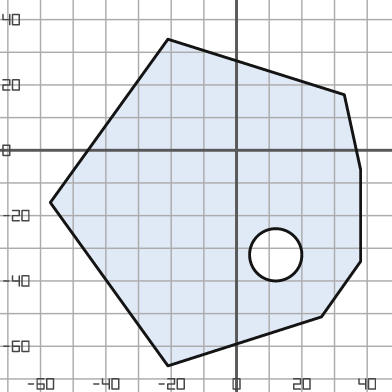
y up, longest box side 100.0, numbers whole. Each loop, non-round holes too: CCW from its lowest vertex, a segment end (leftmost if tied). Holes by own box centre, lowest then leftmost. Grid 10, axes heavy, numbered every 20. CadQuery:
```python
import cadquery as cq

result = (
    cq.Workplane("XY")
    .moveTo(-21.0, -66.0)
    .lineTo(26.0, -51.0)
    .lineTo(38.0, -34.0)
    .lineTo(38.0, -6.0)
    .lineTo(33.0, 17.0)
    .lineTo(-21.0, 34.0)
    .lineTo(-57.0, -16.0)
    .close()
    .moveTo(12.0, -32.0)
    .circle(8.0)
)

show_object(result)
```